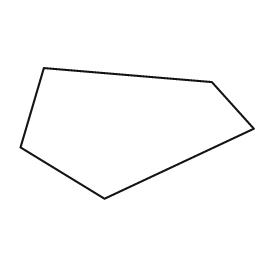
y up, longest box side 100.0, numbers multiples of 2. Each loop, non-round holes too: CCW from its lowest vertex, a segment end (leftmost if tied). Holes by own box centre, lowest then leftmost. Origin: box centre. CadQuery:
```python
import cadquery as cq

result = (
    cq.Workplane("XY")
    .moveTo(-14.0, -28.0)
    .lineTo(50.0, 2.0)
    .lineTo(32.0, 22.0)
    .lineTo(-40.0, 28.0)
    .lineTo(-50.0, -6.0)
    .close()
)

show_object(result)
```